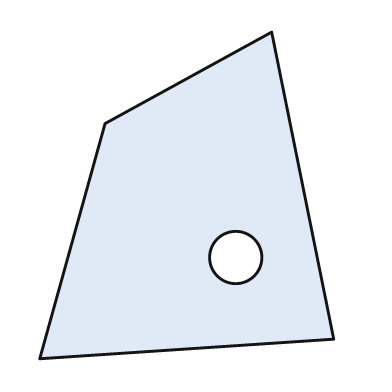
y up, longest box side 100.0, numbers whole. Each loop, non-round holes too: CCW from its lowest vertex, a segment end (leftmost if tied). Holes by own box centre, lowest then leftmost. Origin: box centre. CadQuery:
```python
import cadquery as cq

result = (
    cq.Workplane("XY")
    .moveTo(-45.0, -50.0)
    .lineTo(45.0, -44.0)
    .lineTo(26.0, 50.0)
    .lineTo(-25.0, 22.0)
    .close()
    .moveTo(15.0, -19.0)
    .circle(8.0)
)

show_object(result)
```